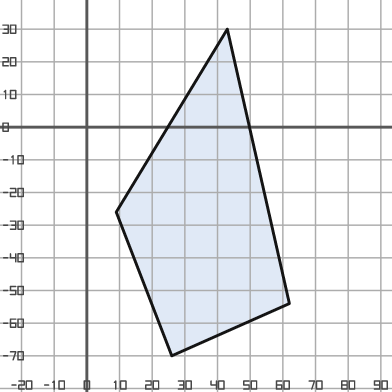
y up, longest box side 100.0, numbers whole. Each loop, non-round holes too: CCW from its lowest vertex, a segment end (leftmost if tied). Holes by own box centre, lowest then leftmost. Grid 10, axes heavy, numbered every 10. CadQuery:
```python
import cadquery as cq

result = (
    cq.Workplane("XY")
    .moveTo(26.0, -70.0)
    .lineTo(62.0, -54.0)
    .lineTo(43.0, 30.0)
    .lineTo(9.0, -26.0)
    .close()
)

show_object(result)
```